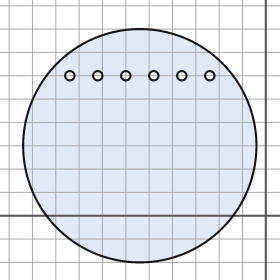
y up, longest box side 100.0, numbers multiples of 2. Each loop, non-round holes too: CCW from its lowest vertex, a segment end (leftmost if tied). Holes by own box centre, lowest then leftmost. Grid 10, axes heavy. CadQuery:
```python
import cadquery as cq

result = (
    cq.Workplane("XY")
    .moveTo(-54.0, 30.0)
    .circle(50.0)
    .moveTo(-84.0, 60.0)
    .circle(2.0)
    .moveTo(-72.0, 60.0)
    .circle(2.0)
    .moveTo(-60.0, 60.0)
    .circle(2.0)
    .moveTo(-48.0, 60.0)
    .circle(2.0)
    .moveTo(-36.0, 60.0)
    .circle(2.0)
    .moveTo(-24.0, 60.0)
    .circle(2.0)
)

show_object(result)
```